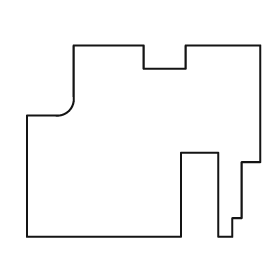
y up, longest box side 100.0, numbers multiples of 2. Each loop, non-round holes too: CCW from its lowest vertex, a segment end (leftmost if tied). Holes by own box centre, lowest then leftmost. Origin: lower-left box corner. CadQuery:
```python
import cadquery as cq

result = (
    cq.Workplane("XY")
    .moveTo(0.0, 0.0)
    .lineTo(66.0, 0.0)
    .lineTo(66.0, 36.0)
    .lineTo(82.0, 36.0)
    .lineTo(82.0, 0.0)
    .lineTo(88.0, 0.0)
    .lineTo(88.0, 8.0)
    .lineTo(92.0, 8.0)
    .lineTo(92.0, 32.0)
    .lineTo(100.0, 32.0)
    .lineTo(100.0, 82.0)
    .lineTo(68.0, 82.0)
    .lineTo(68.0, 72.0)
    .lineTo(50.0, 72.0)
    .lineTo(50.0, 82.0)
    .lineTo(20.0, 82.0)
    .lineTo(20.0, 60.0)
    .threePointArc((18.0, 54.0), (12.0, 52.0))
    .lineTo(0.0, 52.0)
    .close()
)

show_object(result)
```